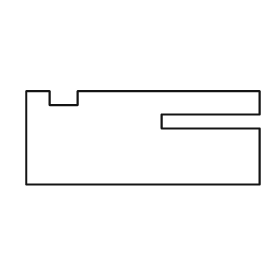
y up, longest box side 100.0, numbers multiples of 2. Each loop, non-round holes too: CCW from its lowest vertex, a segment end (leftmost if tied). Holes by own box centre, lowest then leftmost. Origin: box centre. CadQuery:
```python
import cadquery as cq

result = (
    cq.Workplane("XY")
    .moveTo(-50.0, -20.0)
    .lineTo(50.0, -20.0)
    .lineTo(50.0, 4.0)
    .lineTo(8.0, 4.0)
    .lineTo(8.0, 10.0)
    .lineTo(50.0, 10.0)
    .lineTo(50.0, 20.0)
    .lineTo(-28.0, 20.0)
    .lineTo(-28.0, 14.0)
    .lineTo(-40.0, 14.0)
    .lineTo(-40.0, 20.0)
    .lineTo(-50.0, 20.0)
    .close()
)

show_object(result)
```